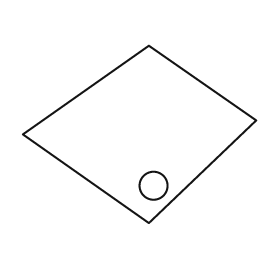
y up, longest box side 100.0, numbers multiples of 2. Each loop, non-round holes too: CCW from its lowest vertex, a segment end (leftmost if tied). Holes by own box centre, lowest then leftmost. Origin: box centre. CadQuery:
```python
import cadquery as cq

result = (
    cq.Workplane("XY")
    .moveTo(4.0, -38.0)
    .lineTo(50.0, 6.0)
    .lineTo(4.0, 38.0)
    .lineTo(-50.0, 0.0)
    .close()
    .moveTo(6.0, -22.0)
    .circle(6.0)
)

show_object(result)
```